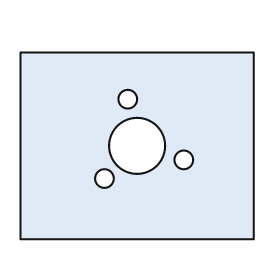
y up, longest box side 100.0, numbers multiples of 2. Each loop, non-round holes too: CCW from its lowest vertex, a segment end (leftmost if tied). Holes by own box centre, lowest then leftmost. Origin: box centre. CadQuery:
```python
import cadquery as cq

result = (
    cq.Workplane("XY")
    .moveTo(-50.0, -40.0)
    .lineTo(50.0, -40.0)
    .lineTo(50.0, 40.0)
    .lineTo(-50.0, 40.0)
    .close()
    .moveTo(-14.0, -14.0)
    .circle(4.0)
    .moveTo(20.0, -6.0)
    .circle(4.0)
    .moveTo(0.0, 0.0)
    .circle(12.0)
    .moveTo(-4.0, 20.0)
    .circle(4.0)
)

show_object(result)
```